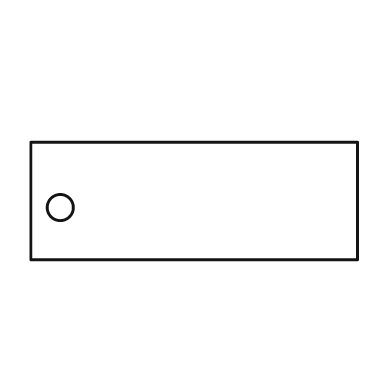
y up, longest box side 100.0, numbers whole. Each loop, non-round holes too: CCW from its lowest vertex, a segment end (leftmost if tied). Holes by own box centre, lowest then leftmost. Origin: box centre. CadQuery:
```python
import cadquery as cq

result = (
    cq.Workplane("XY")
    .moveTo(-50.0, -18.0)
    .lineTo(50.0, -18.0)
    .lineTo(50.0, 18.0)
    .lineTo(-50.0, 18.0)
    .close()
    .moveTo(-41.0, -2.0)
    .circle(4.0)
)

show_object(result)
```